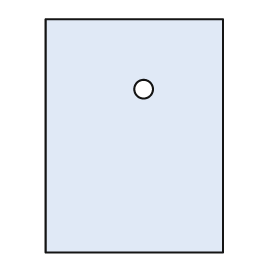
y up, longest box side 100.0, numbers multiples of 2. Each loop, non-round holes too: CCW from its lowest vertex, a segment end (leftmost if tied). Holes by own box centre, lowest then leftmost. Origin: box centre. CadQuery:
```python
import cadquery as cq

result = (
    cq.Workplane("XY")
    .moveTo(-38.0, -50.0)
    .lineTo(38.0, -50.0)
    .lineTo(38.0, 50.0)
    .lineTo(-38.0, 50.0)
    .close()
    .moveTo(4.0, 20.0)
    .circle(4.0)
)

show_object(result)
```